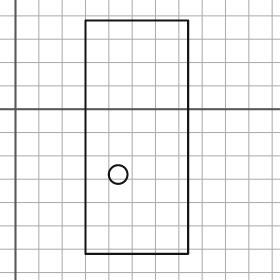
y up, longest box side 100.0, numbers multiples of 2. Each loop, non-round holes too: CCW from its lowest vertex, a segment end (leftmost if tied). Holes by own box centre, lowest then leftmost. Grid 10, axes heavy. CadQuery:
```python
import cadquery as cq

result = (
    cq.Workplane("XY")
    .moveTo(30.0, -62.0)
    .lineTo(74.0, -62.0)
    .lineTo(74.0, 38.0)
    .lineTo(30.0, 38.0)
    .close()
    .moveTo(44.0, -28.0)
    .circle(4.0)
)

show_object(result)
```